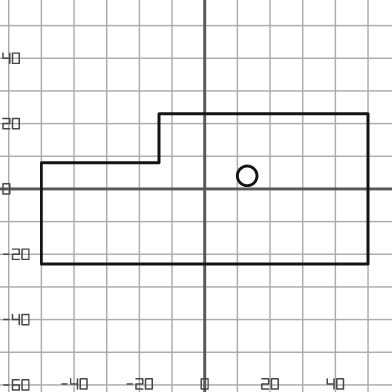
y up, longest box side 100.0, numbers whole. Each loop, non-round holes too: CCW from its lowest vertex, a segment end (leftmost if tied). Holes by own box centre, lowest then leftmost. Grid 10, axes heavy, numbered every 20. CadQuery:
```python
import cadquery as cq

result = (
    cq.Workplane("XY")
    .moveTo(-50.0, -23.0)
    .lineTo(50.0, -23.0)
    .lineTo(50.0, 23.0)
    .lineTo(-14.0, 23.0)
    .lineTo(-14.0, 8.0)
    .lineTo(-50.0, 8.0)
    .close()
    .moveTo(13.0, 4.0)
    .circle(3.0)
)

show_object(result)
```